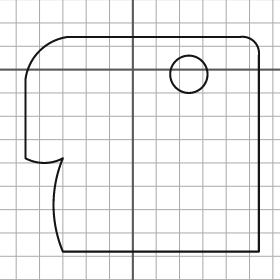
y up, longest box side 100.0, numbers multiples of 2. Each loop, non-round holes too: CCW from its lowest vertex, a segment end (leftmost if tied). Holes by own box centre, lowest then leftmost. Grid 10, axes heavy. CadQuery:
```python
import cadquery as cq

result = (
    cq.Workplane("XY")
    .moveTo(-30.0, -78.0)
    .lineTo(54.0, -78.0)
    .lineTo(54.0, 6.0)
    .threePointArc((52.0, 12.0), (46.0, 14.0))
    .lineTo(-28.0, 14.0)
    .threePointArc((-40.0, 8.0), (-46.0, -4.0))
    .lineTo(-46.0, -38.0)
    .threePointArc((-38.0, -40.0), (-30.0, -38.0))
    .threePointArc((-34.0, -58.0), (-30.0, -78.0))
    .close()
    .moveTo(24.0, -2.0)
    .circle(8.0)
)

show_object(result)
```